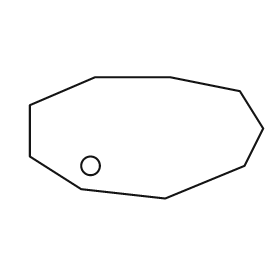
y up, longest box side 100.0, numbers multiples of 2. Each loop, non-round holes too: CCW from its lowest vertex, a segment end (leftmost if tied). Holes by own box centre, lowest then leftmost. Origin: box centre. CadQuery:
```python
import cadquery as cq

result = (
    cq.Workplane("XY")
    .moveTo(8.0, -26.0)
    .lineTo(42.0, -12.0)
    .lineTo(50.0, 4.0)
    .lineTo(40.0, 20.0)
    .lineTo(10.0, 26.0)
    .lineTo(-22.0, 26.0)
    .lineTo(-50.0, 14.0)
    .lineTo(-50.0, -8.0)
    .lineTo(-28.0, -22.0)
    .close()
    .moveTo(-24.0, -12.0)
    .circle(4.0)
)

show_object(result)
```